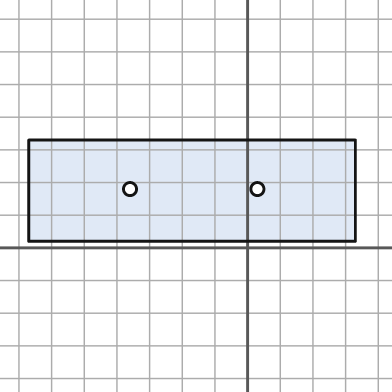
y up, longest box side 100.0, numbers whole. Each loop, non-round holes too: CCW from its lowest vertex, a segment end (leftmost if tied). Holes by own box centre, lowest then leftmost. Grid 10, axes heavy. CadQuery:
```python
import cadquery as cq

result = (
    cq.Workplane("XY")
    .moveTo(-67.0, 2.0)
    .lineTo(33.0, 2.0)
    .lineTo(33.0, 33.0)
    .lineTo(-67.0, 33.0)
    .close()
    .moveTo(-36.0, 18.0)
    .circle(2.0)
    .moveTo(3.0, 18.0)
    .circle(2.0)
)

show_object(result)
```